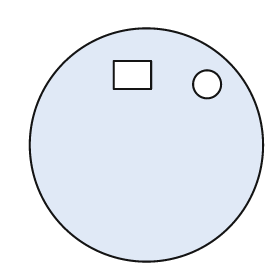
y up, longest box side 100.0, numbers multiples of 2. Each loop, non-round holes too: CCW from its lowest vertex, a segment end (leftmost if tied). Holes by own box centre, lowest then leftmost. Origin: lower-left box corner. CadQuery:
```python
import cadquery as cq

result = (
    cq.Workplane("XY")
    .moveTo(50.0, 50.0)
    .circle(50.0)
    .moveTo(76.0, 76.0)
    .circle(6.0)
    .moveTo(36.0, 74.0)
    .lineTo(52.0, 74.0)
    .lineTo(52.0, 86.0)
    .lineTo(36.0, 86.0)
    .close()
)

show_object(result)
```